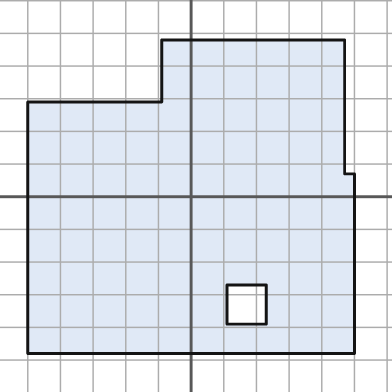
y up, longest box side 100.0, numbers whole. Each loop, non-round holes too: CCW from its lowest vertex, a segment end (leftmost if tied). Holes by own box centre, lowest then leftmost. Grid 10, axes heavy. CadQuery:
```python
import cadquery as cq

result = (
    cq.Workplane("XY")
    .moveTo(-50.0, -48.0)
    .lineTo(50.0, -48.0)
    .lineTo(50.0, 7.0)
    .lineTo(47.0, 7.0)
    .lineTo(47.0, 48.0)
    .lineTo(-9.0, 48.0)
    .lineTo(-9.0, 29.0)
    .lineTo(-50.0, 29.0)
    .close()
    .moveTo(11.0, -39.0)
    .lineTo(23.0, -39.0)
    .lineTo(23.0, -27.0)
    .lineTo(11.0, -27.0)
    .close()
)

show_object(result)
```